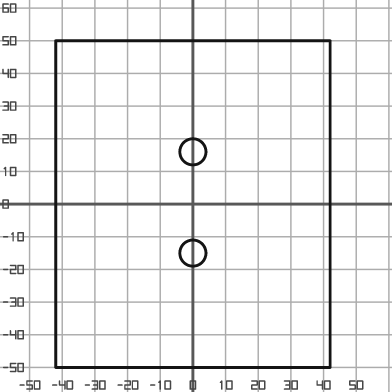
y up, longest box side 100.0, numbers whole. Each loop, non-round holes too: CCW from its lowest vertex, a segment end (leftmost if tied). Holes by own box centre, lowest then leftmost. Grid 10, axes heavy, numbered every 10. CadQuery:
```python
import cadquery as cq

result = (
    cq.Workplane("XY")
    .moveTo(-42.0, -50.0)
    .lineTo(42.0, -50.0)
    .lineTo(42.0, 50.0)
    .lineTo(-42.0, 50.0)
    .close()
    .moveTo(0.0, -15.0)
    .circle(4.0)
    .moveTo(0.0, 16.0)
    .circle(4.0)
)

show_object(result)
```